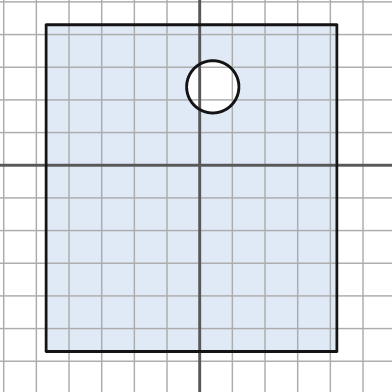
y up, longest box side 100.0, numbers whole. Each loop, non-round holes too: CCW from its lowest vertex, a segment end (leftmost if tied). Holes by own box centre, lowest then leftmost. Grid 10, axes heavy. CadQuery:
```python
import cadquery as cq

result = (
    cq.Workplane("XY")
    .moveTo(-47.0, -57.0)
    .lineTo(42.0, -57.0)
    .lineTo(42.0, 43.0)
    .lineTo(-47.0, 43.0)
    .close()
    .moveTo(4.0, 24.0)
    .circle(8.0)
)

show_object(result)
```